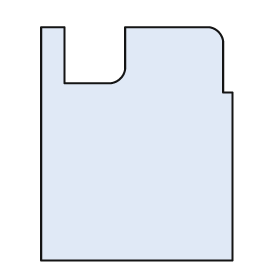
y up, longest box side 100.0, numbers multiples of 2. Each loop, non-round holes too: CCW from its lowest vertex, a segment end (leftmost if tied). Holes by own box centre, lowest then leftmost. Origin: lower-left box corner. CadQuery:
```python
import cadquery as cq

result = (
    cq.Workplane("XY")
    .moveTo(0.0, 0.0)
    .lineTo(82.0, 0.0)
    .lineTo(82.0, 72.0)
    .lineTo(78.0, 72.0)
    .lineTo(78.0, 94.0)
    .threePointArc((76.0, 98.0), (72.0, 100.0))
    .lineTo(36.0, 100.0)
    .lineTo(36.0, 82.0)
    .threePointArc((34.0, 78.0), (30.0, 76.0))
    .lineTo(10.0, 76.0)
    .lineTo(10.0, 100.0)
    .lineTo(0.0, 100.0)
    .close()
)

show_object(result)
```